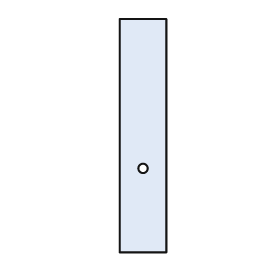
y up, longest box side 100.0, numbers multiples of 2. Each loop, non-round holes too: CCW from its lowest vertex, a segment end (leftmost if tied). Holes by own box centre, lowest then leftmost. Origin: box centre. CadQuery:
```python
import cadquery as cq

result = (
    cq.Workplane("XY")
    .moveTo(-10.0, -50.0)
    .lineTo(10.0, -50.0)
    .lineTo(10.0, 50.0)
    .lineTo(-10.0, 50.0)
    .close()
    .moveTo(0.0, -14.0)
    .circle(2.0)
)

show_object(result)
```